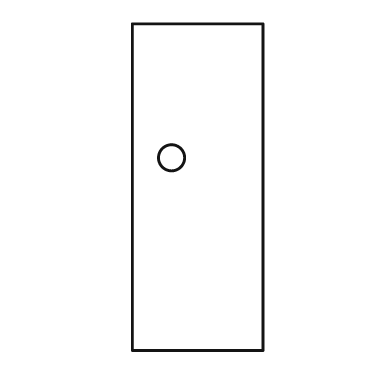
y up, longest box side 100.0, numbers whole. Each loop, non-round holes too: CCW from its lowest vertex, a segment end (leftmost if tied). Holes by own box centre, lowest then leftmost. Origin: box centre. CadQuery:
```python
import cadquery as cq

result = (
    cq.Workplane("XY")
    .moveTo(-20.0, -50.0)
    .lineTo(20.0, -50.0)
    .lineTo(20.0, 50.0)
    .lineTo(-20.0, 50.0)
    .close()
    .moveTo(-8.0, 9.0)
    .circle(4.0)
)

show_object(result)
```